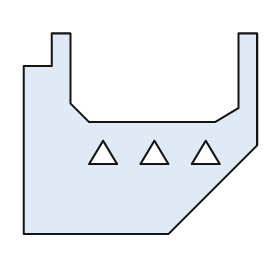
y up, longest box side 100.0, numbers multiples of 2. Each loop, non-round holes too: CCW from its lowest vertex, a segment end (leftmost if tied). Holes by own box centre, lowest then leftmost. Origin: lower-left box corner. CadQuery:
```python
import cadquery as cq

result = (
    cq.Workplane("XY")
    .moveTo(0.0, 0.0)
    .lineTo(62.0, 0.0)
    .lineTo(100.0, 38.0)
    .lineTo(100.0, 86.0)
    .lineTo(92.0, 86.0)
    .lineTo(92.0, 54.0)
    .lineTo(82.0, 48.0)
    .lineTo(28.0, 48.0)
    .lineTo(20.0, 56.0)
    .lineTo(20.0, 86.0)
    .lineTo(12.0, 86.0)
    .lineTo(12.0, 72.0)
    .lineTo(0.0, 72.0)
    .close()
    .moveTo(28.0, 30.0)
    .lineTo(40.0, 30.0)
    .lineTo(34.0, 40.0)
    .close()
    .moveTo(50.0, 30.0)
    .lineTo(62.0, 30.0)
    .lineTo(56.0, 40.0)
    .close()
    .moveTo(72.0, 30.0)
    .lineTo(84.0, 30.0)
    .lineTo(78.0, 40.0)
    .close()
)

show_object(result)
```